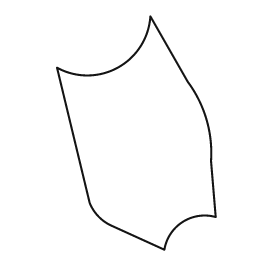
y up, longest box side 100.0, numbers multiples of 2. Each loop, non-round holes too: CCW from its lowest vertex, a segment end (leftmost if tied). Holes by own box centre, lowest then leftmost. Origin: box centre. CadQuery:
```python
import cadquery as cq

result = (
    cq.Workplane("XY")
    .moveTo(12.0, -50.0)
    .threePointArc((20.0, -38.0), (34.0, -36.0))
    .lineTo(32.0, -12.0)
    .threePointArc((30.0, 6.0), (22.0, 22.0))
    .lineTo(6.0, 50.0)
    .threePointArc((-8.0, 28.0), (-34.0, 28.0))
    .lineTo(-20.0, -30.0)
    .threePointArc((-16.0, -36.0), (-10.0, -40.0))
    .close()
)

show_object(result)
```